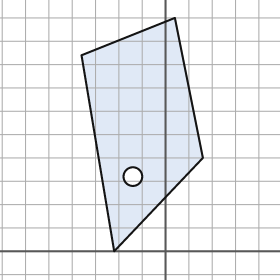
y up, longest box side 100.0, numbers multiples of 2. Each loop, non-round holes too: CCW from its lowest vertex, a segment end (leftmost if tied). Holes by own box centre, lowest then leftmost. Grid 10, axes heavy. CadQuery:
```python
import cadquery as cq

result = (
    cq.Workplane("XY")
    .moveTo(-22.0, 0.0)
    .lineTo(16.0, 40.0)
    .lineTo(4.0, 100.0)
    .lineTo(-36.0, 84.0)
    .close()
    .moveTo(-14.0, 32.0)
    .circle(4.0)
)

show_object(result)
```